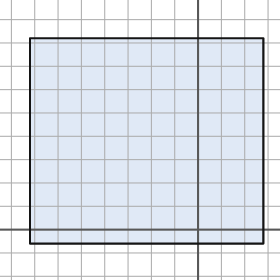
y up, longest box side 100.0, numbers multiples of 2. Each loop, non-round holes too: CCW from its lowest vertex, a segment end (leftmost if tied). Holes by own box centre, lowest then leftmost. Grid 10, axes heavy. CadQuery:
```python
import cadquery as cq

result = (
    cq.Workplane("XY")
    .moveTo(-72.0, -6.0)
    .lineTo(28.0, -6.0)
    .lineTo(28.0, 82.0)
    .lineTo(-72.0, 82.0)
    .close()
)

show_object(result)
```